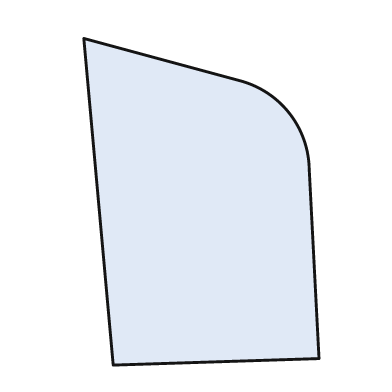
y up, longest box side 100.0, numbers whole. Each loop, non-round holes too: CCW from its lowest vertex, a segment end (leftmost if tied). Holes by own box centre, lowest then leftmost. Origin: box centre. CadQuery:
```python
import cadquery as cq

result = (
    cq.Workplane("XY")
    .moveTo(-27.0, -50.0)
    .lineTo(36.0, -48.0)
    .lineTo(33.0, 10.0)
    .threePointArc((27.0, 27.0), (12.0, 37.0))
    .lineTo(-36.0, 50.0)
    .close()
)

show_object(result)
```